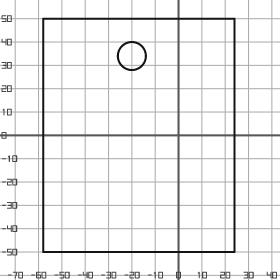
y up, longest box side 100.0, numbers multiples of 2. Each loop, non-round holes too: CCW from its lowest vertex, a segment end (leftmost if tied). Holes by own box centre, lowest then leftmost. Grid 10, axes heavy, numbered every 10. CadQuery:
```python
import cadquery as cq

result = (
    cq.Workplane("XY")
    .moveTo(-58.0, -50.0)
    .lineTo(24.0, -50.0)
    .lineTo(24.0, 50.0)
    .lineTo(-58.0, 50.0)
    .close()
    .moveTo(-20.0, 34.0)
    .circle(6.0)
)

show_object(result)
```